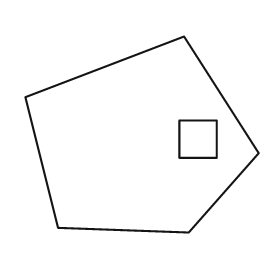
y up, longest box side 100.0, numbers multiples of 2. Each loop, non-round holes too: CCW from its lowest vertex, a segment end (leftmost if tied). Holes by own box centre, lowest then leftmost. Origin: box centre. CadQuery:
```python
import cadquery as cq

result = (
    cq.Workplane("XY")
    .moveTo(20.0, -42.0)
    .lineTo(50.0, -8.0)
    .lineTo(18.0, 42.0)
    .lineTo(-50.0, 16.0)
    .lineTo(-36.0, -40.0)
    .close()
    .moveTo(16.0, -10.0)
    .lineTo(32.0, -10.0)
    .lineTo(32.0, 6.0)
    .lineTo(16.0, 6.0)
    .close()
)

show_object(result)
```